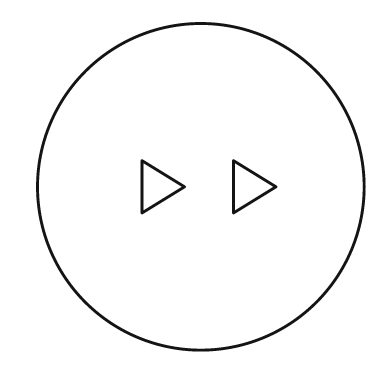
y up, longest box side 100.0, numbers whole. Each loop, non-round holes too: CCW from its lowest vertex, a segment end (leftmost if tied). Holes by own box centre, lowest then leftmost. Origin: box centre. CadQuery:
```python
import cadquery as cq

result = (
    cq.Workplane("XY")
    .moveTo(0.0, 0.0)
    .circle(50.0)
    .moveTo(-18.0, -8.0)
    .lineTo(-5.0, 0.0)
    .lineTo(-18.0, 8.0)
    .close()
    .moveTo(10.0, -8.0)
    .lineTo(23.0, 0.0)
    .lineTo(10.0, 8.0)
    .close()
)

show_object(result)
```